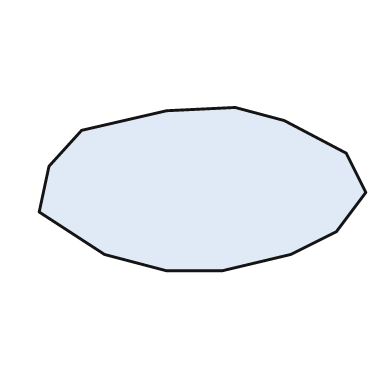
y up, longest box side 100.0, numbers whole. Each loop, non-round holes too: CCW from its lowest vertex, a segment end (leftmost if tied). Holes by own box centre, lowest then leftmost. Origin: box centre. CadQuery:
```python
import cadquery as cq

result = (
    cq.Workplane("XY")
    .moveTo(-11.0, -25.0)
    .lineTo(6.0, -25.0)
    .lineTo(27.0, -20.0)
    .lineTo(41.0, -13.0)
    .lineTo(50.0, -1.0)
    .lineTo(44.0, 11.0)
    .lineTo(25.0, 21.0)
    .lineTo(10.0, 25.0)
    .lineTo(-11.0, 24.0)
    .lineTo(-37.0, 18.0)
    .lineTo(-47.0, 7.0)
    .lineTo(-50.0, -7.0)
    .lineTo(-30.0, -20.0)
    .close()
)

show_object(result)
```